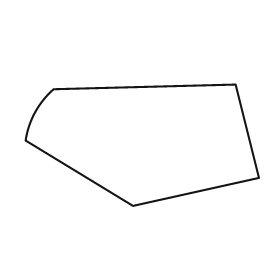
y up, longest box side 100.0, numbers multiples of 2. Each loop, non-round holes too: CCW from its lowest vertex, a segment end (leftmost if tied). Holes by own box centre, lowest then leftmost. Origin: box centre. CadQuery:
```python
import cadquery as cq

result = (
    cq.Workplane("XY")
    .moveTo(-4.0, -26.0)
    .lineTo(50.0, -14.0)
    .lineTo(40.0, 26.0)
    .lineTo(-38.0, 24.0)
    .threePointArc((-46.0, 14.0), (-50.0, 2.0))
    .close()
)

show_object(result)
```